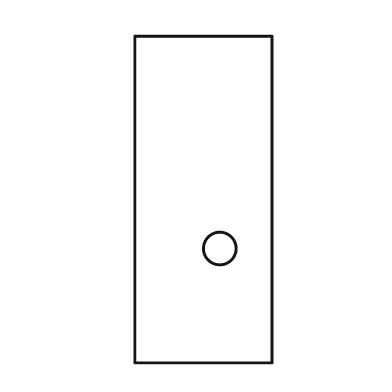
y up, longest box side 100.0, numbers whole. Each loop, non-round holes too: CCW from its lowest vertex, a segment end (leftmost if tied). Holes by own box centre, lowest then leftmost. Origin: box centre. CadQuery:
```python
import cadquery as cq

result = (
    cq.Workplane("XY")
    .moveTo(-21.0, -50.0)
    .lineTo(21.0, -50.0)
    .lineTo(21.0, 50.0)
    .lineTo(-21.0, 50.0)
    .close()
    .moveTo(5.0, -15.0)
    .circle(5.0)
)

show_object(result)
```